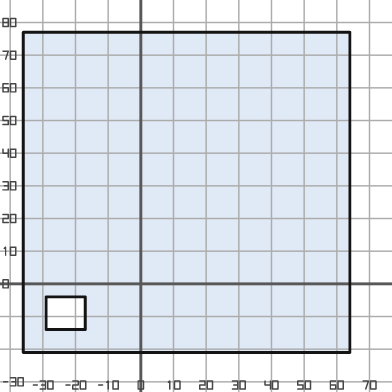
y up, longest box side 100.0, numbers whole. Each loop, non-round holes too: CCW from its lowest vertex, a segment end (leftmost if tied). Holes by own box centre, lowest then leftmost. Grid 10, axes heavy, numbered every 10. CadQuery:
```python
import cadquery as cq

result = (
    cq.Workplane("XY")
    .moveTo(-36.0, -21.0)
    .lineTo(64.0, -21.0)
    .lineTo(64.0, 77.0)
    .lineTo(-36.0, 77.0)
    .close()
    .moveTo(-29.0, -14.0)
    .lineTo(-17.0, -14.0)
    .lineTo(-17.0, -4.0)
    .lineTo(-29.0, -4.0)
    .close()
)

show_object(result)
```